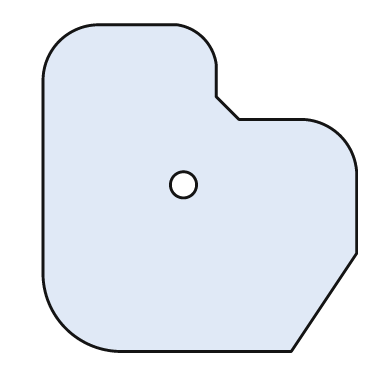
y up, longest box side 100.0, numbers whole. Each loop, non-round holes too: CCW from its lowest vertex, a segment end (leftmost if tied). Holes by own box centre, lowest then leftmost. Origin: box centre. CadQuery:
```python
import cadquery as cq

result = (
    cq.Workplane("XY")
    .moveTo(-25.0, -50.0)
    .lineTo(28.0, -50.0)
    .lineTo(48.0, -20.0)
    .lineTo(48.0, 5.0)
    .threePointArc((43.0, 16.0), (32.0, 21.0))
    .lineTo(12.0, 21.0)
    .lineTo(5.0, 28.0)
    .lineTo(5.0, 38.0)
    .threePointArc((1.0, 46.0), (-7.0, 50.0))
    .lineTo(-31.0, 50.0)
    .threePointArc((-43.0, 45.0), (-48.0, 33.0))
    .lineTo(-48.0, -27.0)
    .threePointArc((-41.0, -43.0), (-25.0, -50.0))
    .close()
    .moveTo(-5.0, 1.0)
    .circle(4.0)
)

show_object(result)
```